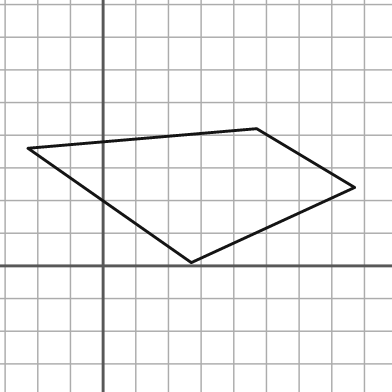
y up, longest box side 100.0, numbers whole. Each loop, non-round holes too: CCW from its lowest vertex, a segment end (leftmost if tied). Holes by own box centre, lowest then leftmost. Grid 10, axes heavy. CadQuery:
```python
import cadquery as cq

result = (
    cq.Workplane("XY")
    .moveTo(27.0, 1.0)
    .lineTo(77.0, 24.0)
    .lineTo(47.0, 42.0)
    .lineTo(-23.0, 36.0)
    .close()
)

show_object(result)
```